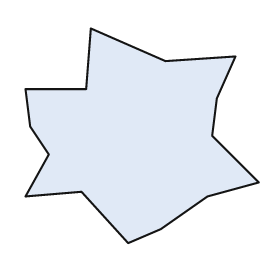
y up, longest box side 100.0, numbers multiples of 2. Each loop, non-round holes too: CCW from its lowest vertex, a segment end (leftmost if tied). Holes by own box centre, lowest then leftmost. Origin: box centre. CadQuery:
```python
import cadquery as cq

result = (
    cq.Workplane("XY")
    .moveTo(-6.0, -46.0)
    .lineTo(8.0, -40.0)
    .lineTo(28.0, -26.0)
    .lineTo(50.0, -20.0)
    .lineTo(30.0, 0.0)
    .lineTo(32.0, 16.0)
    .lineTo(40.0, 34.0)
    .lineTo(10.0, 32.0)
    .lineTo(-22.0, 46.0)
    .lineTo(-24.0, 20.0)
    .lineTo(-50.0, 20.0)
    .lineTo(-48.0, 4.0)
    .lineTo(-40.0, -8.0)
    .lineTo(-50.0, -26.0)
    .lineTo(-26.0, -24.0)
    .close()
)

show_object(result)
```